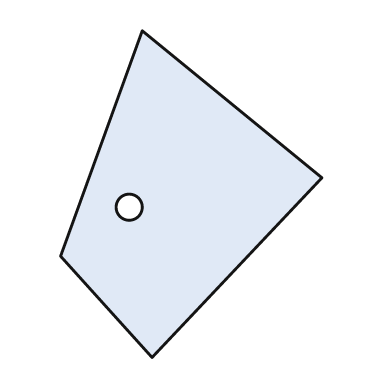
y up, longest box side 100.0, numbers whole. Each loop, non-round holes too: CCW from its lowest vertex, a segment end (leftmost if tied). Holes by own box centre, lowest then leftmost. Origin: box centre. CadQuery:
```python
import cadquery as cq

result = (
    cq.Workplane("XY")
    .moveTo(-12.0, -50.0)
    .lineTo(40.0, 5.0)
    .lineTo(-15.0, 50.0)
    .lineTo(-40.0, -19.0)
    .close()
    .moveTo(-19.0, -4.0)
    .circle(4.0)
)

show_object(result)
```